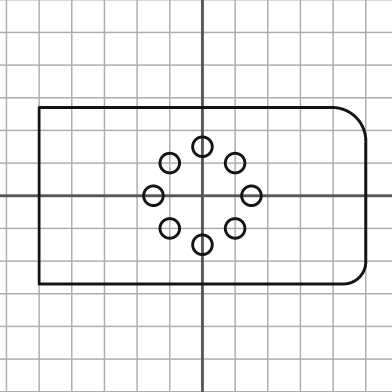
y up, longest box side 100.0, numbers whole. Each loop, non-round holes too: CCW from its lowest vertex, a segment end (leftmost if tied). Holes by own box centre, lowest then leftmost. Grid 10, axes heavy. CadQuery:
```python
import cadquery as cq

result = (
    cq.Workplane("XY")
    .moveTo(-50.0, -27.0)
    .lineTo(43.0, -27.0)
    .threePointArc((48.0, -25.0), (50.0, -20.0))
    .lineTo(50.0, 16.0)
    .threePointArc((47.0, 24.0), (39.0, 27.0))
    .lineTo(-50.0, 27.0)
    .close()
    .moveTo(0.0, -15.0)
    .circle(3.0)
    .moveTo(-10.0, -10.0)
    .circle(3.0)
    .moveTo(10.0, -10.0)
    .circle(3.0)
    .moveTo(-15.0, 0.0)
    .circle(3.0)
    .moveTo(15.0, 0.0)
    .circle(3.0)
    .moveTo(-10.0, 10.0)
    .circle(3.0)
    .moveTo(10.0, 10.0)
    .circle(3.0)
    .moveTo(0.0, 15.0)
    .circle(3.0)
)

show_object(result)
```